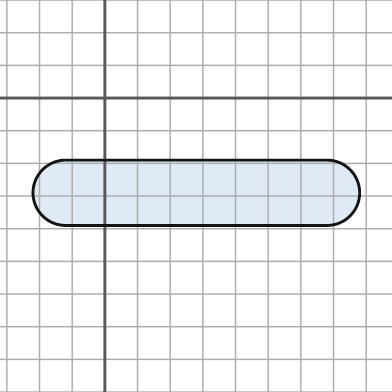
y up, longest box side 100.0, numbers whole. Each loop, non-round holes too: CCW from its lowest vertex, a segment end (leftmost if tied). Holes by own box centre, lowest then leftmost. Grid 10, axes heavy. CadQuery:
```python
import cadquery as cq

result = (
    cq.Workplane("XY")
    .moveTo(-12.0, -39.0)
    .lineTo(68.0, -39.0)
    .threePointArc((78.0, -29.0), (68.0, -19.0))
    .lineTo(-12.0, -19.0)
    .threePointArc((-22.0, -29.0), (-12.0, -39.0))
    .close()
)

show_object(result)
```